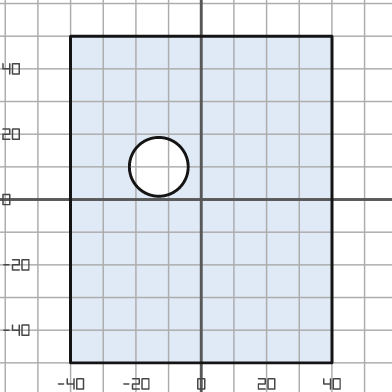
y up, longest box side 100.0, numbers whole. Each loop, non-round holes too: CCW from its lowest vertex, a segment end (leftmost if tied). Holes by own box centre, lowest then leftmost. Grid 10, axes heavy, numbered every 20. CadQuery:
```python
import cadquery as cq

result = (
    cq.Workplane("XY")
    .moveTo(-40.0, -50.0)
    .lineTo(40.0, -50.0)
    .lineTo(40.0, 50.0)
    .lineTo(-40.0, 50.0)
    .close()
    .moveTo(-13.0, 10.0)
    .circle(9.0)
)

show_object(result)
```